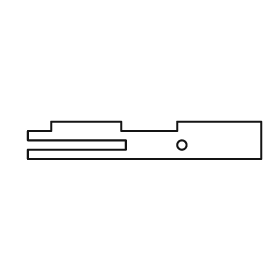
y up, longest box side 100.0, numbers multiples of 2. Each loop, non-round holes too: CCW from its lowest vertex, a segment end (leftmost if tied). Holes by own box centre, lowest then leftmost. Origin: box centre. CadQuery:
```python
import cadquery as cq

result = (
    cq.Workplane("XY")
    .moveTo(-50.0, -8.0)
    .lineTo(50.0, -8.0)
    .lineTo(50.0, 8.0)
    .lineTo(14.0, 8.0)
    .lineTo(14.0, 4.0)
    .lineTo(-10.0, 4.0)
    .lineTo(-10.0, 8.0)
    .lineTo(-40.0, 8.0)
    .lineTo(-40.0, 4.0)
    .lineTo(-50.0, 4.0)
    .lineTo(-50.0, 0.0)
    .lineTo(-8.0, 0.0)
    .lineTo(-8.0, -4.0)
    .lineTo(-50.0, -4.0)
    .close()
    .moveTo(16.0, -2.0)
    .circle(2.0)
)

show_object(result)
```